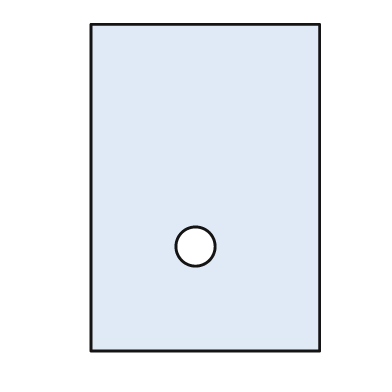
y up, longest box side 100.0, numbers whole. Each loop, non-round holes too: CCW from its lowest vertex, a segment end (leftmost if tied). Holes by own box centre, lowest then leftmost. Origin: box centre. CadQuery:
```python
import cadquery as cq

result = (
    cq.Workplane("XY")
    .moveTo(-35.0, -50.0)
    .lineTo(35.0, -50.0)
    .lineTo(35.0, 50.0)
    .lineTo(-35.0, 50.0)
    .close()
    .moveTo(-3.0, -18.0)
    .circle(6.0)
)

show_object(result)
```